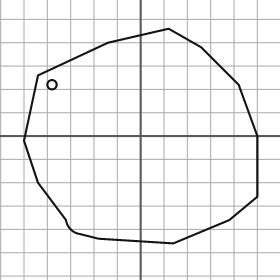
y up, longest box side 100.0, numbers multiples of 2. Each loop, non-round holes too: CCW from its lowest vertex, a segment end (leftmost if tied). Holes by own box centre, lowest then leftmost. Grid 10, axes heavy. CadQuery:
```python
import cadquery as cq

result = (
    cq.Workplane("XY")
    .moveTo(14.0, -46.0)
    .lineTo(38.0, -36.0)
    .lineTo(50.0, -26.0)
    .lineTo(50.0, 0.0)
    .lineTo(42.0, 22.0)
    .lineTo(26.0, 38.0)
    .lineTo(12.0, 46.0)
    .lineTo(-14.0, 40.0)
    .lineTo(-44.0, 26.0)
    .lineTo(-50.0, -2.0)
    .lineTo(-44.0, -20.0)
    .lineTo(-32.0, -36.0)
    .threePointArc((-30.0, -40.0), (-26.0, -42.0))
    .lineTo(-18.0, -44.0)
    .close()
    .moveTo(-38.0, 22.0)
    .circle(2.0)
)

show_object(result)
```